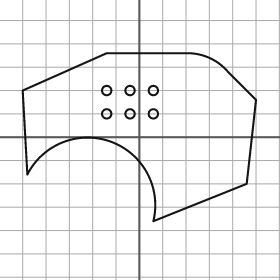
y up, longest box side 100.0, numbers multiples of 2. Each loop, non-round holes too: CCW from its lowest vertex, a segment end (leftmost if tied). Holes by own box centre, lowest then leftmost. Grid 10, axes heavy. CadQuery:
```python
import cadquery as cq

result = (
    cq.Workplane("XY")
    .moveTo(6.0, -36.0)
    .lineTo(46.0, -20.0)
    .lineTo(50.0, 16.0)
    .lineTo(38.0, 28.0)
    .threePointArc((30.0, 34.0), (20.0, 36.0))
    .lineTo(-14.0, 36.0)
    .lineTo(-50.0, 20.0)
    .lineTo(-48.0, -16.0)
    .threePointArc((-12.0, -2.0), (6.0, -36.0))
    .close()
    .moveTo(-14.0, 10.0)
    .circle(2.0)
    .moveTo(-4.0, 10.0)
    .circle(2.0)
    .moveTo(6.0, 10.0)
    .circle(2.0)
    .moveTo(-14.0, 20.0)
    .circle(2.0)
    .moveTo(-4.0, 20.0)
    .circle(2.0)
    .moveTo(6.0, 20.0)
    .circle(2.0)
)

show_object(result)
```